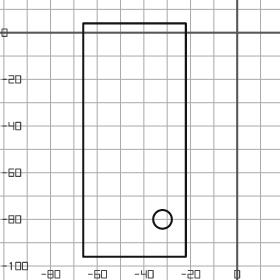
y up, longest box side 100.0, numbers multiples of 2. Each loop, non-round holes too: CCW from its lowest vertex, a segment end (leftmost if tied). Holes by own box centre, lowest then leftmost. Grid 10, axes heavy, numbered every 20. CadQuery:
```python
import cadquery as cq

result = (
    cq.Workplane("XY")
    .moveTo(-66.0, -96.0)
    .lineTo(-22.0, -96.0)
    .lineTo(-22.0, 4.0)
    .lineTo(-66.0, 4.0)
    .close()
    .moveTo(-32.0, -80.0)
    .circle(4.0)
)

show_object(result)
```